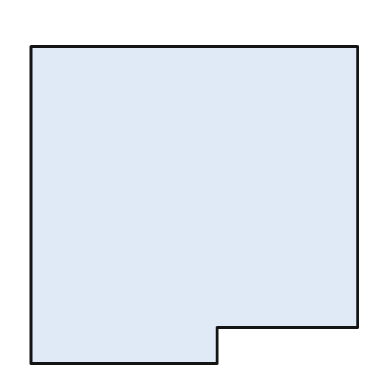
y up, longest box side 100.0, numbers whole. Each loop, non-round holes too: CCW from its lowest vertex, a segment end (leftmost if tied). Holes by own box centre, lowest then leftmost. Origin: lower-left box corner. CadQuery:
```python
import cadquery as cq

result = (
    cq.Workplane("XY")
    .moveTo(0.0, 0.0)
    .lineTo(57.0, 0.0)
    .lineTo(57.0, 11.0)
    .lineTo(100.0, 11.0)
    .lineTo(100.0, 97.0)
    .lineTo(0.0, 97.0)
    .close()
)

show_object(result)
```